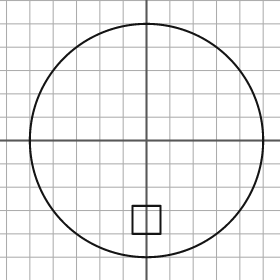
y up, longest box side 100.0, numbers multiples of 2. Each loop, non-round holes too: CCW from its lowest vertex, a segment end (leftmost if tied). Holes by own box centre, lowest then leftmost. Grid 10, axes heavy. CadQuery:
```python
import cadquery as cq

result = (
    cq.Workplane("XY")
    .moveTo(0.0, 0.0)
    .circle(50.0)
    .moveTo(-6.0, -40.0)
    .lineTo(6.0, -40.0)
    .lineTo(6.0, -28.0)
    .lineTo(-6.0, -28.0)
    .close()
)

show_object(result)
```